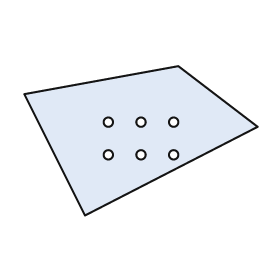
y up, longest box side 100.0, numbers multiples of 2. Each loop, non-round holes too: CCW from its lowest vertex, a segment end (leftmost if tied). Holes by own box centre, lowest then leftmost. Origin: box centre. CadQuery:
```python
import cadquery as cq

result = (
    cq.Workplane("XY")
    .moveTo(-24.0, -32.0)
    .lineTo(50.0, 6.0)
    .lineTo(16.0, 32.0)
    .lineTo(-50.0, 20.0)
    .close()
    .moveTo(-14.0, -6.0)
    .circle(2.0)
    .moveTo(0.0, -6.0)
    .circle(2.0)
    .moveTo(14.0, -6.0)
    .circle(2.0)
    .moveTo(-14.0, 8.0)
    .circle(2.0)
    .moveTo(0.0, 8.0)
    .circle(2.0)
    .moveTo(14.0, 8.0)
    .circle(2.0)
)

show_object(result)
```